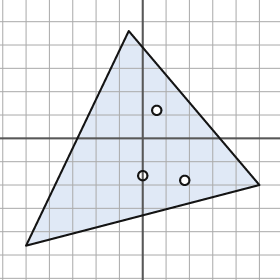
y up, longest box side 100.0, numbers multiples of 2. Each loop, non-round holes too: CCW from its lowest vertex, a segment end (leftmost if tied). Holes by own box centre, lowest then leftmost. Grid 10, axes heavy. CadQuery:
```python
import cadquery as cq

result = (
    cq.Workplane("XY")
    .moveTo(-50.0, -46.0)
    .lineTo(50.0, -20.0)
    .lineTo(-6.0, 46.0)
    .close()
    .moveTo(18.0, -18.0)
    .circle(2.0)
    .moveTo(0.0, -16.0)
    .circle(2.0)
    .moveTo(6.0, 12.0)
    .circle(2.0)
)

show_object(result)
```